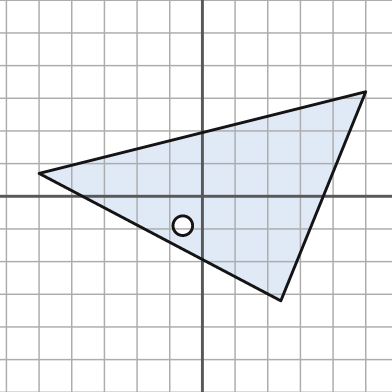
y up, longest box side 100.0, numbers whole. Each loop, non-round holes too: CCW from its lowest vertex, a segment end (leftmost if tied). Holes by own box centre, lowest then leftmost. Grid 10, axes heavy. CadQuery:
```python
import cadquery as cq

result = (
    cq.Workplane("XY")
    .moveTo(24.0, -32.0)
    .lineTo(50.0, 32.0)
    .lineTo(-50.0, 7.0)
    .close()
    .moveTo(-6.0, -9.0)
    .circle(3.0)
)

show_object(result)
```